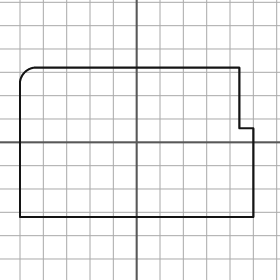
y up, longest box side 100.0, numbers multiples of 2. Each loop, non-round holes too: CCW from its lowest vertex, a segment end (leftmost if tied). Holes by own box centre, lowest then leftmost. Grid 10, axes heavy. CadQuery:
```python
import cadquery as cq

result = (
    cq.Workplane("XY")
    .moveTo(-50.0, -32.0)
    .lineTo(50.0, -32.0)
    .lineTo(50.0, 6.0)
    .lineTo(44.0, 6.0)
    .lineTo(44.0, 32.0)
    .lineTo(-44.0, 32.0)
    .threePointArc((-48.0, 30.0), (-50.0, 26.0))
    .close()
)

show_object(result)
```